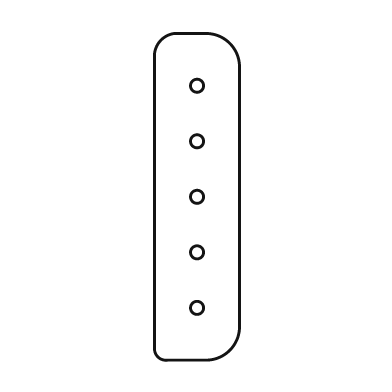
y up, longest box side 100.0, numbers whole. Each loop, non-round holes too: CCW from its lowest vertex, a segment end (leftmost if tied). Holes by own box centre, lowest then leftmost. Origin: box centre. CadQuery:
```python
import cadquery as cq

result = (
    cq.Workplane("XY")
    .moveTo(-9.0, -50.0)
    .lineTo(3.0, -50.0)
    .threePointArc((10.0, -47.0), (13.0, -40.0))
    .lineTo(13.0, 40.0)
    .threePointArc((10.0, 47.0), (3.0, 50.0))
    .lineTo(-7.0, 50.0)
    .threePointArc((-11.0, 48.0), (-13.0, 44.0))
    .lineTo(-13.0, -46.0)
    .threePointArc((-12.0, -49.0), (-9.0, -50.0))
    .close()
    .moveTo(0.0, -34.0)
    .circle(2.0)
    .moveTo(0.0, -17.0)
    .circle(2.0)
    .moveTo(0.0, 0.0)
    .circle(2.0)
    .moveTo(0.0, 17.0)
    .circle(2.0)
    .moveTo(0.0, 34.0)
    .circle(2.0)
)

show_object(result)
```